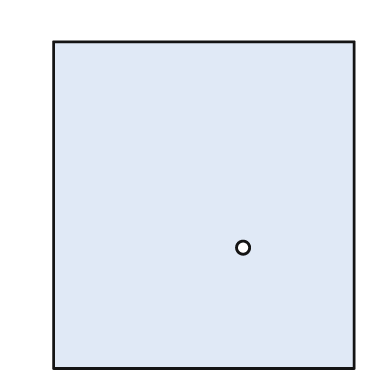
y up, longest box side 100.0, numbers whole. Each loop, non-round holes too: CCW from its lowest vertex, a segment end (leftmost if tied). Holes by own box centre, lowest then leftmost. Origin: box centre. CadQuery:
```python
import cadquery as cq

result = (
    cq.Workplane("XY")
    .moveTo(-46.0, -50.0)
    .lineTo(46.0, -50.0)
    .lineTo(46.0, 50.0)
    .lineTo(-46.0, 50.0)
    .close()
    .moveTo(12.0, -13.0)
    .circle(2.0)
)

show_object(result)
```